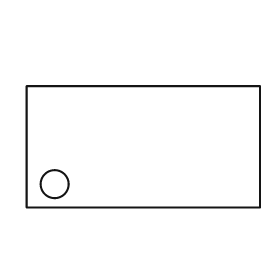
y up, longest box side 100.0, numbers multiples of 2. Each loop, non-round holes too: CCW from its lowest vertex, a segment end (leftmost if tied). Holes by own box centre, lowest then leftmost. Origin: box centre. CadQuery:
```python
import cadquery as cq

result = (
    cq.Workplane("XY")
    .moveTo(-50.0, -26.0)
    .lineTo(50.0, -26.0)
    .lineTo(50.0, 26.0)
    .lineTo(-50.0, 26.0)
    .close()
    .moveTo(-38.0, -16.0)
    .circle(6.0)
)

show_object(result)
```